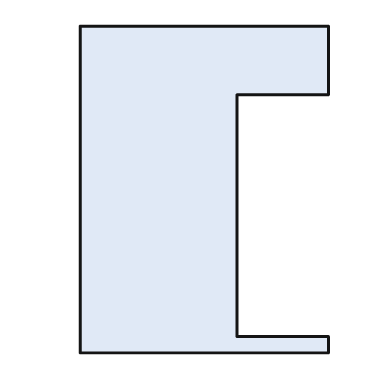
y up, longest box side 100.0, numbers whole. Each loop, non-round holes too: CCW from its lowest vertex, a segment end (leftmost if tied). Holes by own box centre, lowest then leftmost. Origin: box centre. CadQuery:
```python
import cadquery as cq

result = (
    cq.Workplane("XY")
    .moveTo(-38.0, -50.0)
    .lineTo(38.0, -50.0)
    .lineTo(38.0, -45.0)
    .lineTo(10.0, -45.0)
    .lineTo(10.0, 29.0)
    .lineTo(38.0, 29.0)
    .lineTo(38.0, 50.0)
    .lineTo(-38.0, 50.0)
    .close()
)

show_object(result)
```